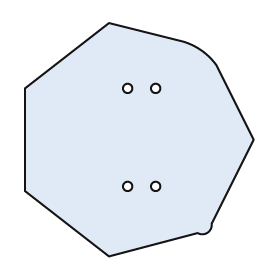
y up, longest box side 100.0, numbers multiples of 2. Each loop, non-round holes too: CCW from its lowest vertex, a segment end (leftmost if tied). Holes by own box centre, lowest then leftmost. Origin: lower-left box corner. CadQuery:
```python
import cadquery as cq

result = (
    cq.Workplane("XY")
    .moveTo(36.0, 0.0)
    .lineTo(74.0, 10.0)
    .threePointArc((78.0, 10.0), (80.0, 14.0))
    .lineTo(98.0, 50.0)
    .lineTo(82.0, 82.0)
    .threePointArc((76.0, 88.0), (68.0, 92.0))
    .lineTo(36.0, 100.0)
    .lineTo(0.0, 72.0)
    .lineTo(0.0, 28.0)
    .close()
    .moveTo(44.0, 30.0)
    .circle(2.0)
    .moveTo(56.0, 30.0)
    .circle(2.0)
    .moveTo(44.0, 72.0)
    .circle(2.0)
    .moveTo(56.0, 72.0)
    .circle(2.0)
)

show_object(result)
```